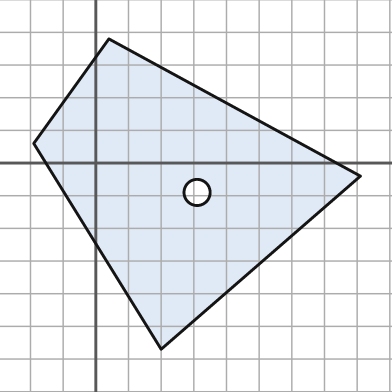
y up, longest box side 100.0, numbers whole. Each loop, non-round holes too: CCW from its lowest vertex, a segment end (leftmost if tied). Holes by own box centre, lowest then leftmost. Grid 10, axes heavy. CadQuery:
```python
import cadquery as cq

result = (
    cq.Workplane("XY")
    .moveTo(20.0, -57.0)
    .lineTo(81.0, -4.0)
    .lineTo(4.0, 38.0)
    .lineTo(-19.0, 6.0)
    .close()
    .moveTo(31.0, -9.0)
    .circle(4.0)
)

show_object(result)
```